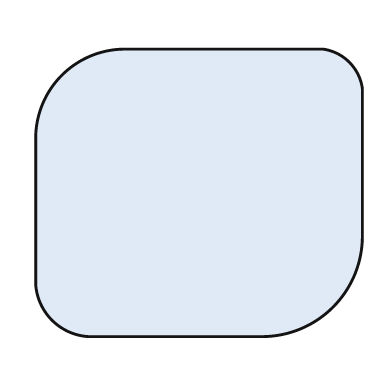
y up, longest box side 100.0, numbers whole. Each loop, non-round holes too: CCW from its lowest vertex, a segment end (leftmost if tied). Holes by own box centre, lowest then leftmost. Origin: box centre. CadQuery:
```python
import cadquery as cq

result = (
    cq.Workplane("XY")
    .moveTo(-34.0, -44.0)
    .lineTo(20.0, -44.0)
    .threePointArc((41.0, -35.0), (50.0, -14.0))
    .lineTo(50.0, 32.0)
    .threePointArc((46.0, 40.0), (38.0, 44.0))
    .lineTo(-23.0, 44.0)
    .threePointArc((-42.0, 36.0), (-50.0, 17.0))
    .lineTo(-50.0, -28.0)
    .threePointArc((-45.0, -39.0), (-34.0, -44.0))
    .close()
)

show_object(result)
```